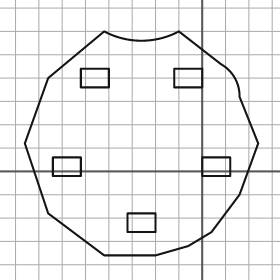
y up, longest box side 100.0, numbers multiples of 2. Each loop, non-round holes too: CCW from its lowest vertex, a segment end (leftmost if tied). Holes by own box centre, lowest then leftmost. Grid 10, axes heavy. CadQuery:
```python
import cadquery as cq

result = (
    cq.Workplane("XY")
    .moveTo(-42.0, -36.0)
    .lineTo(-20.0, -36.0)
    .lineTo(-6.0, -32.0)
    .lineTo(4.0, -26.0)
    .lineTo(16.0, -10.0)
    .lineTo(24.0, 12.0)
    .lineTo(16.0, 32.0)
    .threePointArc((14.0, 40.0), (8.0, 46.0))
    .lineTo(-10.0, 60.0)
    .threePointArc((-26.0, 56.0), (-42.0, 60.0))
    .lineTo(-66.0, 40.0)
    .lineTo(-76.0, 12.0)
    .lineTo(-66.0, -18.0)
    .close()
    .moveTo(-32.0, -26.0)
    .lineTo(-20.0, -26.0)
    .lineTo(-20.0, -18.0)
    .lineTo(-32.0, -18.0)
    .close()
    .moveTo(-64.0, -2.0)
    .lineTo(-52.0, -2.0)
    .lineTo(-52.0, 6.0)
    .lineTo(-64.0, 6.0)
    .close()
    .moveTo(0.0, -2.0)
    .lineTo(12.0, -2.0)
    .lineTo(12.0, 6.0)
    .lineTo(0.0, 6.0)
    .close()
    .moveTo(-52.0, 36.0)
    .lineTo(-40.0, 36.0)
    .lineTo(-40.0, 44.0)
    .lineTo(-52.0, 44.0)
    .close()
    .moveTo(-12.0, 36.0)
    .lineTo(0.0, 36.0)
    .lineTo(0.0, 44.0)
    .lineTo(-12.0, 44.0)
    .close()
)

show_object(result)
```